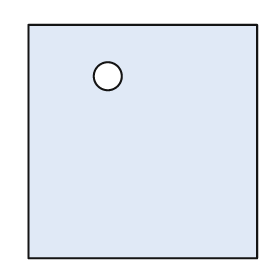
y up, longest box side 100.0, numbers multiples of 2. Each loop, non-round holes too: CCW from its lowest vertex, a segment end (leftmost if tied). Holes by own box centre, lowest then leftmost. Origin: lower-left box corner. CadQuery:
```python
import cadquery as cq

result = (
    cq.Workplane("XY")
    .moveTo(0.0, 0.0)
    .lineTo(98.0, 0.0)
    .lineTo(98.0, 100.0)
    .lineTo(0.0, 100.0)
    .close()
    .moveTo(34.0, 78.0)
    .circle(6.0)
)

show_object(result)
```